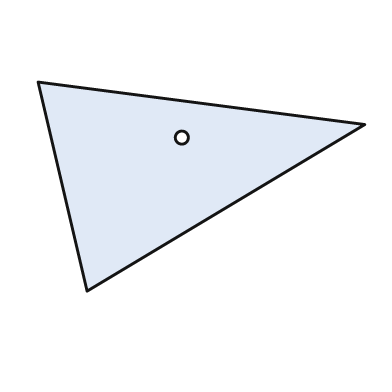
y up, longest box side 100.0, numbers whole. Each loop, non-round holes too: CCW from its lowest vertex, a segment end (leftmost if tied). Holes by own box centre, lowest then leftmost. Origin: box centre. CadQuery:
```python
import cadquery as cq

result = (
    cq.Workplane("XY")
    .moveTo(-35.0, -32.0)
    .lineTo(50.0, 19.0)
    .lineTo(-50.0, 32.0)
    .close()
    .moveTo(-6.0, 15.0)
    .circle(2.0)
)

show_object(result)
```